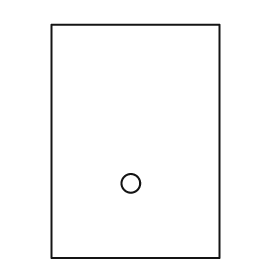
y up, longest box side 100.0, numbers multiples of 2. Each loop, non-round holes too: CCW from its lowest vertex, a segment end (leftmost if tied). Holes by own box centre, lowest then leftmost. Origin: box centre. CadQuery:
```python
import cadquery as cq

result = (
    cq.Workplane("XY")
    .moveTo(-36.0, -50.0)
    .lineTo(36.0, -50.0)
    .lineTo(36.0, 50.0)
    .lineTo(-36.0, 50.0)
    .close()
    .moveTo(-2.0, -18.0)
    .circle(4.0)
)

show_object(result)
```